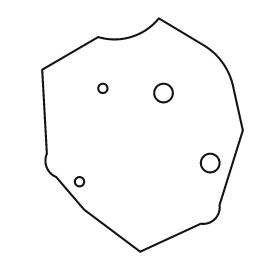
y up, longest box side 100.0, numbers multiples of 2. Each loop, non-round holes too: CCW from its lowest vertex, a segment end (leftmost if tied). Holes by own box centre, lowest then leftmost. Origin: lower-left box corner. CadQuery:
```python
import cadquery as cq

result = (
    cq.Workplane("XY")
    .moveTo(42.0, 0.0)
    .lineTo(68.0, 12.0)
    .threePointArc((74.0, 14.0), (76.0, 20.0))
    .lineTo(86.0, 52.0)
    .lineTo(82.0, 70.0)
    .threePointArc((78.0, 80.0), (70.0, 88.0))
    .lineTo(50.0, 100.0)
    .threePointArc((38.0, 92.0), (24.0, 92.0))
    .lineTo(0.0, 78.0)
    .lineTo(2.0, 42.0)
    .threePointArc((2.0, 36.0), (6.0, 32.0))
    .lineTo(18.0, 18.0)
    .close()
    .moveTo(16.0, 30.0)
    .circle(2.0)
    .moveTo(72.0, 38.0)
    .circle(4.0)
    .moveTo(52.0, 68.0)
    .circle(4.0)
    .moveTo(26.0, 70.0)
    .circle(2.0)
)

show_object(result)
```